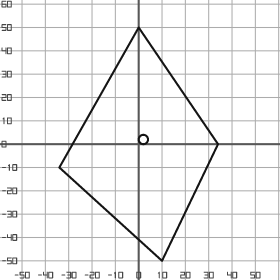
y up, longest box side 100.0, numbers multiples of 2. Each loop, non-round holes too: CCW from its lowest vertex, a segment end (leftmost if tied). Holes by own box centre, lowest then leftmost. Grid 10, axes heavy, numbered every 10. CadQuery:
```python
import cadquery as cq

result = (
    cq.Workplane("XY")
    .moveTo(10.0, -50.0)
    .lineTo(34.0, 0.0)
    .lineTo(0.0, 50.0)
    .lineTo(-34.0, -10.0)
    .close()
    .moveTo(2.0, 2.0)
    .circle(2.0)
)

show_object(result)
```